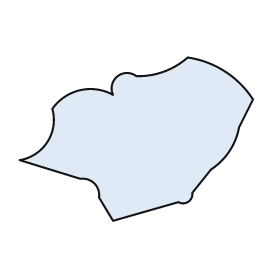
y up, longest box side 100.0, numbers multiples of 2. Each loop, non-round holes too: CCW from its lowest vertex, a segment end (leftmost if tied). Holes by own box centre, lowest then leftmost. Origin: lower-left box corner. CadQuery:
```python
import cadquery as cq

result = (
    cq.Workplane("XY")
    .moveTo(40.0, 0.0)
    .lineTo(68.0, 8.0)
    .threePointArc((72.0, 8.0), (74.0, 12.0))
    .lineTo(82.0, 22.0)
    .threePointArc((90.0, 30.0), (94.0, 40.0))
    .lineTo(100.0, 52.0)
    .threePointArc((88.0, 64.0), (72.0, 70.0))
    .threePointArc((62.0, 64.0), (50.0, 62.0))
    .threePointArc((42.0, 62.0), (40.0, 54.0))
    .threePointArc((26.0, 56.0), (14.0, 48.0))
    .threePointArc((12.0, 34.0), (0.0, 26.0))
    .lineTo(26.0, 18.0)
    .threePointArc((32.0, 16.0), (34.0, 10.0))
    .close()
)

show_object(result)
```